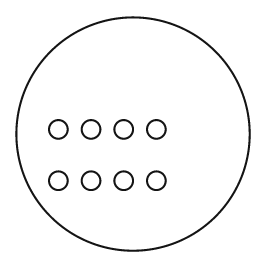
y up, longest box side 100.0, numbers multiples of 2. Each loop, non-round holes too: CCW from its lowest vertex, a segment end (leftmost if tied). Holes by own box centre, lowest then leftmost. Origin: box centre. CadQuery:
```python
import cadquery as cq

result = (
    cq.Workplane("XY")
    .moveTo(0.0, 0.0)
    .circle(50.0)
    .moveTo(-32.0, -20.0)
    .circle(4.0)
    .moveTo(-18.0, -20.0)
    .circle(4.0)
    .moveTo(-4.0, -20.0)
    .circle(4.0)
    .moveTo(10.0, -20.0)
    .circle(4.0)
    .moveTo(-32.0, 2.0)
    .circle(4.0)
    .moveTo(-18.0, 2.0)
    .circle(4.0)
    .moveTo(-4.0, 2.0)
    .circle(4.0)
    .moveTo(10.0, 2.0)
    .circle(4.0)
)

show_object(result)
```